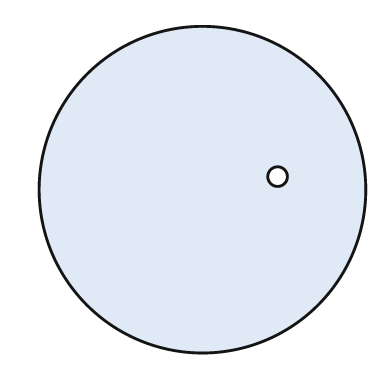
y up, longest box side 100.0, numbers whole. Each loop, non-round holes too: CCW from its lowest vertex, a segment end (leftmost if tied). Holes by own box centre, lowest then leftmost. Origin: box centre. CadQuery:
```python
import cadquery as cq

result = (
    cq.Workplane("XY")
    .moveTo(0.0, 0.0)
    .circle(50.0)
    .moveTo(23.0, 4.0)
    .circle(3.0)
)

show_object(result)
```